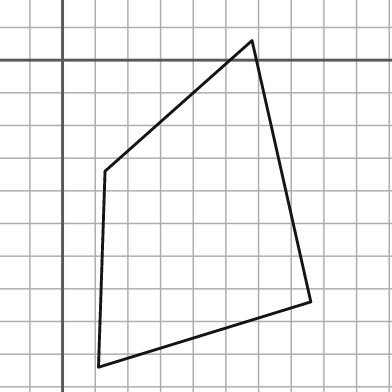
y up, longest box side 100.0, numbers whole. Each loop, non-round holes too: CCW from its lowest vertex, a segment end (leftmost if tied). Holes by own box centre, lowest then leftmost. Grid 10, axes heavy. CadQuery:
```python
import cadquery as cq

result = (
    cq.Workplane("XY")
    .moveTo(11.0, -94.0)
    .lineTo(76.0, -74.0)
    .lineTo(58.0, 6.0)
    .lineTo(13.0, -34.0)
    .close()
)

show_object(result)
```